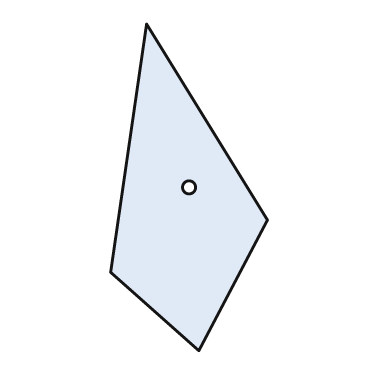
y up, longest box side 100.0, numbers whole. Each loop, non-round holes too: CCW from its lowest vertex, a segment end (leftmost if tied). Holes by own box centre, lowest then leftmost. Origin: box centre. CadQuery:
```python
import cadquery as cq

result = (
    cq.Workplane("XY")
    .moveTo(3.0, -50.0)
    .lineTo(24.0, -10.0)
    .lineTo(-13.0, 50.0)
    .lineTo(-24.0, -26.0)
    .close()
    .moveTo(0.0, 0.0)
    .circle(2.0)
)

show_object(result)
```